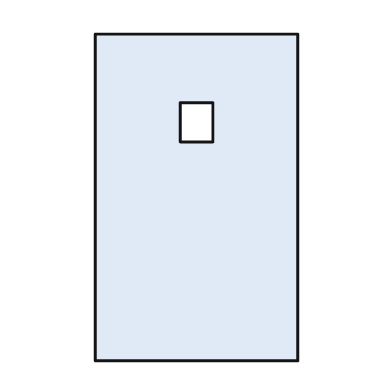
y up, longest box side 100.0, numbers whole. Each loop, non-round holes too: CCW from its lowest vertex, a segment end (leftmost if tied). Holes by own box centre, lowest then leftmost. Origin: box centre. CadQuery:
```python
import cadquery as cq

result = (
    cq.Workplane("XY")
    .moveTo(-31.0, -50.0)
    .lineTo(31.0, -50.0)
    .lineTo(31.0, 50.0)
    .lineTo(-31.0, 50.0)
    .close()
    .moveTo(-5.0, 17.0)
    .lineTo(5.0, 17.0)
    .lineTo(5.0, 29.0)
    .lineTo(-5.0, 29.0)
    .close()
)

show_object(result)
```